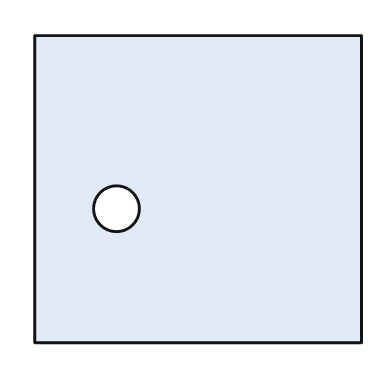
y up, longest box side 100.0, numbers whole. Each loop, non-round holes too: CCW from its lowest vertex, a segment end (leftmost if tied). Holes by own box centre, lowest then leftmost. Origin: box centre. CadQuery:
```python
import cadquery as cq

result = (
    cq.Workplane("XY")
    .moveTo(-50.0, -47.0)
    .lineTo(50.0, -47.0)
    .lineTo(50.0, 47.0)
    .lineTo(-50.0, 47.0)
    .close()
    .moveTo(-25.0, -6.0)
    .circle(7.0)
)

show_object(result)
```